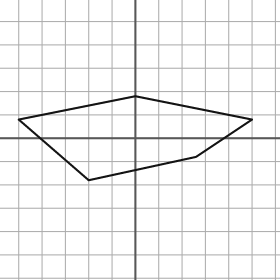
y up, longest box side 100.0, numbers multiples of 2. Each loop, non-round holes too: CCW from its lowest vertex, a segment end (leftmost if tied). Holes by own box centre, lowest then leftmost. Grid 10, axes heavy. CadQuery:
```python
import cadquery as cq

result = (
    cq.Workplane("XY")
    .moveTo(-20.0, -18.0)
    .lineTo(26.0, -8.0)
    .lineTo(50.0, 8.0)
    .lineTo(0.0, 18.0)
    .lineTo(-50.0, 8.0)
    .close()
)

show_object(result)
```